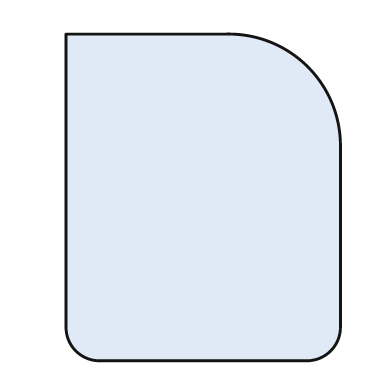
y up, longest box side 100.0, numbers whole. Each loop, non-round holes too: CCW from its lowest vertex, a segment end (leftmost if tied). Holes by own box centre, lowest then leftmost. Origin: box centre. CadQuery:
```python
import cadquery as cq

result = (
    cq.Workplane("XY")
    .moveTo(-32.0, -50.0)
    .lineTo(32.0, -50.0)
    .threePointArc((39.0, -47.0), (42.0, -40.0))
    .lineTo(42.0, 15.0)
    .threePointArc((32.0, 40.0), (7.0, 50.0))
    .lineTo(-42.0, 50.0)
    .lineTo(-42.0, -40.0)
    .threePointArc((-39.0, -47.0), (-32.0, -50.0))
    .close()
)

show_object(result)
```